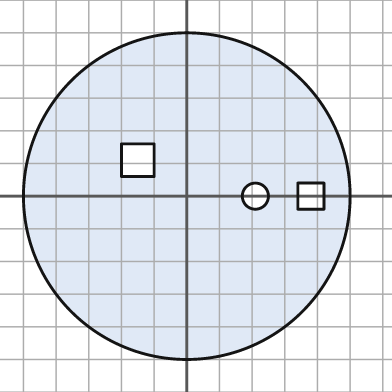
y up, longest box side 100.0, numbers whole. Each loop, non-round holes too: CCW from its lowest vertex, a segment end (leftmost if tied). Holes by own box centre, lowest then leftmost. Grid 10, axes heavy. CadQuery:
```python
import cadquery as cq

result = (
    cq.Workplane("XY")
    .moveTo(0.0, 0.0)
    .circle(50.0)
    .moveTo(21.0, 0.0)
    .circle(4.0)
    .moveTo(34.0, -4.0)
    .lineTo(42.0, -4.0)
    .lineTo(42.0, 4.0)
    .lineTo(34.0, 4.0)
    .close()
    .moveTo(-20.0, 6.0)
    .lineTo(-10.0, 6.0)
    .lineTo(-10.0, 16.0)
    .lineTo(-20.0, 16.0)
    .close()
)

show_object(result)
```